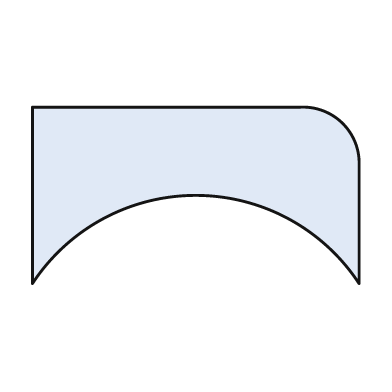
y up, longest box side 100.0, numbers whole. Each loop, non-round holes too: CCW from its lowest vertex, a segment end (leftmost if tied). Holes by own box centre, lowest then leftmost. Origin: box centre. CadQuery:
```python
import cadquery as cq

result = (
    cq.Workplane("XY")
    .moveTo(-50.0, -27.0)
    .threePointArc((0.0, 0.0), (50.0, -27.0))
    .lineTo(50.0, 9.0)
    .threePointArc((45.0, 22.0), (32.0, 27.0))
    .lineTo(-50.0, 27.0)
    .close()
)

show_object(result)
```